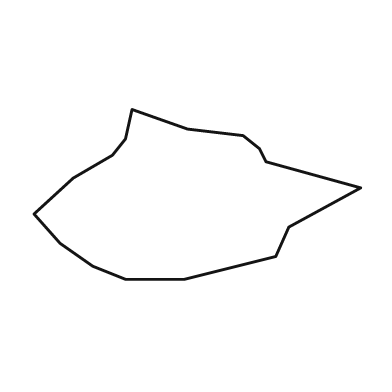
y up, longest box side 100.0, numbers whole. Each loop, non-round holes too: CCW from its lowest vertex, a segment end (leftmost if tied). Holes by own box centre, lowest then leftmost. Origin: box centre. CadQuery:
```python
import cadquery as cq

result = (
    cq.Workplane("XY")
    .moveTo(-22.0, -26.0)
    .lineTo(-4.0, -26.0)
    .lineTo(24.0, -19.0)
    .lineTo(28.0, -10.0)
    .lineTo(50.0, 2.0)
    .lineTo(21.0, 10.0)
    .lineTo(19.0, 14.0)
    .lineTo(14.0, 18.0)
    .lineTo(-3.0, 20.0)
    .lineTo(-20.0, 26.0)
    .lineTo(-22.0, 17.0)
    .lineTo(-26.0, 12.0)
    .lineTo(-38.0, 5.0)
    .lineTo(-50.0, -6.0)
    .lineTo(-42.0, -15.0)
    .lineTo(-32.0, -22.0)
    .close()
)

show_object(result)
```